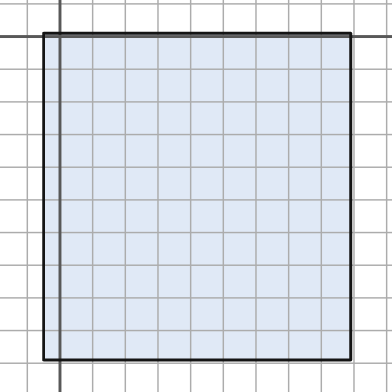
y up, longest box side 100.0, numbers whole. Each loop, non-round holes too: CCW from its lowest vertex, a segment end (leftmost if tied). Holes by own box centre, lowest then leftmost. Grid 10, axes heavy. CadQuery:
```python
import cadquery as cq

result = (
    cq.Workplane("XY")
    .moveTo(-5.0, -99.0)
    .lineTo(89.0, -99.0)
    .lineTo(89.0, 1.0)
    .lineTo(-5.0, 1.0)
    .close()
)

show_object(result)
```